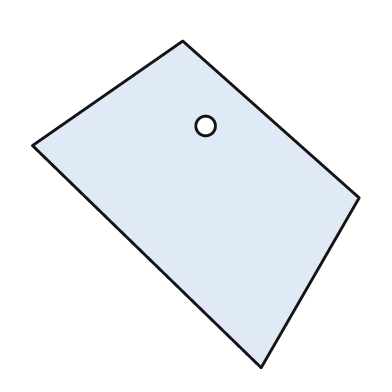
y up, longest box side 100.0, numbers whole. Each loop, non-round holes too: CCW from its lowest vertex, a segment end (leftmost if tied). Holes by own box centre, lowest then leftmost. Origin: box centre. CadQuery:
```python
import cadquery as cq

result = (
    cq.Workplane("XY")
    .moveTo(20.0, -50.0)
    .lineTo(50.0, 2.0)
    .lineTo(-4.0, 50.0)
    .lineTo(-50.0, 18.0)
    .close()
    .moveTo(3.0, 24.0)
    .circle(3.0)
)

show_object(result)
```